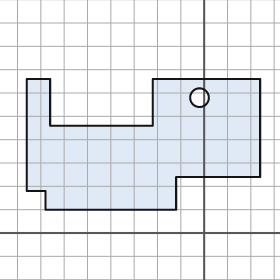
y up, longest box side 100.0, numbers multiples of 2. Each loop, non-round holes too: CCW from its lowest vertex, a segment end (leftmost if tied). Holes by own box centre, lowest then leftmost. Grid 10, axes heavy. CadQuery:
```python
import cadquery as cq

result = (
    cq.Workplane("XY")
    .moveTo(-68.0, 10.0)
    .lineTo(-12.0, 10.0)
    .lineTo(-12.0, 24.0)
    .lineTo(24.0, 24.0)
    .lineTo(24.0, 66.0)
    .lineTo(-22.0, 66.0)
    .lineTo(-22.0, 46.0)
    .lineTo(-66.0, 46.0)
    .lineTo(-66.0, 66.0)
    .lineTo(-76.0, 66.0)
    .lineTo(-76.0, 18.0)
    .lineTo(-68.0, 18.0)
    .close()
    .moveTo(-2.0, 58.0)
    .circle(4.0)
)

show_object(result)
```